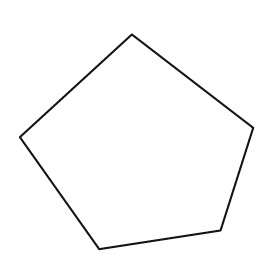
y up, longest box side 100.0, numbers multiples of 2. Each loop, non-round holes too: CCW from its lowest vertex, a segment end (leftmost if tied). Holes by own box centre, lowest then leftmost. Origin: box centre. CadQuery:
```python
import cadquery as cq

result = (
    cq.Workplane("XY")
    .moveTo(-16.0, -46.0)
    .lineTo(36.0, -38.0)
    .lineTo(50.0, 6.0)
    .lineTo(-2.0, 46.0)
    .lineTo(-50.0, 2.0)
    .close()
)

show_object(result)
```